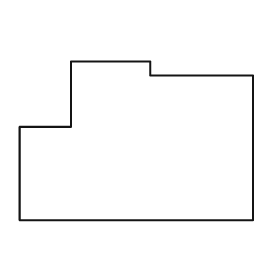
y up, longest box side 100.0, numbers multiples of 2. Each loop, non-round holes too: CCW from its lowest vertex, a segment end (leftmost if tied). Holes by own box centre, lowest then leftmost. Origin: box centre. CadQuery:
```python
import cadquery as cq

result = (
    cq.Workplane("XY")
    .moveTo(-50.0, -34.0)
    .lineTo(50.0, -34.0)
    .lineTo(50.0, 28.0)
    .lineTo(6.0, 28.0)
    .lineTo(6.0, 34.0)
    .lineTo(-28.0, 34.0)
    .lineTo(-28.0, 6.0)
    .lineTo(-50.0, 6.0)
    .close()
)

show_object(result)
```